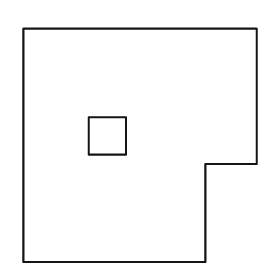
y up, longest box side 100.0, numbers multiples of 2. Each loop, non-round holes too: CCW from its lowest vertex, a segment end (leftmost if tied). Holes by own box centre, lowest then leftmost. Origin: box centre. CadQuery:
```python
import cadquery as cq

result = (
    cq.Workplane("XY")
    .moveTo(-50.0, -50.0)
    .lineTo(28.0, -50.0)
    .lineTo(28.0, -8.0)
    .lineTo(50.0, -8.0)
    .lineTo(50.0, 50.0)
    .lineTo(-50.0, 50.0)
    .close()
    .moveTo(-22.0, -4.0)
    .lineTo(-6.0, -4.0)
    .lineTo(-6.0, 12.0)
    .lineTo(-22.0, 12.0)
    .close()
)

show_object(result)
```